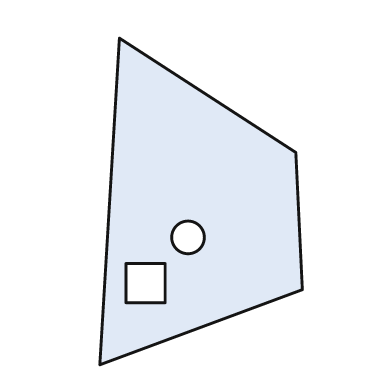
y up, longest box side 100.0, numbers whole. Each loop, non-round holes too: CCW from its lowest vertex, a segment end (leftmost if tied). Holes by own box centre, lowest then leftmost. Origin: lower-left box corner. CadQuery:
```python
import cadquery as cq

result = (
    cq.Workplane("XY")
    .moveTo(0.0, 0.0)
    .lineTo(62.0, 23.0)
    .lineTo(60.0, 65.0)
    .lineTo(6.0, 100.0)
    .close()
    .moveTo(8.0, 19.0)
    .lineTo(20.0, 19.0)
    .lineTo(20.0, 31.0)
    .lineTo(8.0, 31.0)
    .close()
    .moveTo(27.0, 39.0)
    .circle(5.0)
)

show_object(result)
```